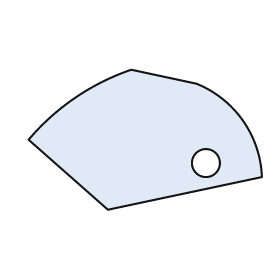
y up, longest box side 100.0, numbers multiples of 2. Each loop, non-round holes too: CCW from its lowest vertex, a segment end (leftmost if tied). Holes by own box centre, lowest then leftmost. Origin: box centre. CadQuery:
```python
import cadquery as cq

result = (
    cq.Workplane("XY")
    .moveTo(-16.0, -30.0)
    .lineTo(50.0, -16.0)
    .threePointArc((42.0, 8.0), (22.0, 24.0))
    .lineTo(-6.0, 30.0)
    .threePointArc((-30.0, 18.0), (-50.0, 0.0))
    .close()
    .moveTo(26.0, -10.0)
    .circle(6.0)
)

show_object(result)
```